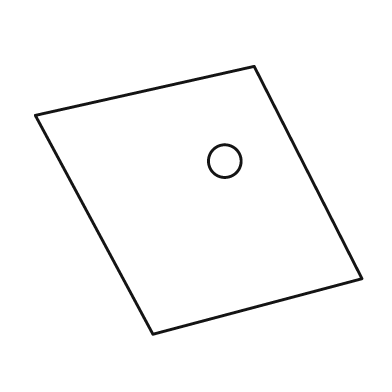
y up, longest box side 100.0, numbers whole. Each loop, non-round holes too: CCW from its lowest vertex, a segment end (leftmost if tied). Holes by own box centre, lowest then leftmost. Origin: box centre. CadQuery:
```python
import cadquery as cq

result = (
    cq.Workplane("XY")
    .moveTo(-14.0, -41.0)
    .lineTo(50.0, -24.0)
    .lineTo(17.0, 41.0)
    .lineTo(-50.0, 26.0)
    .close()
    .moveTo(8.0, 12.0)
    .circle(5.0)
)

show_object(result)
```